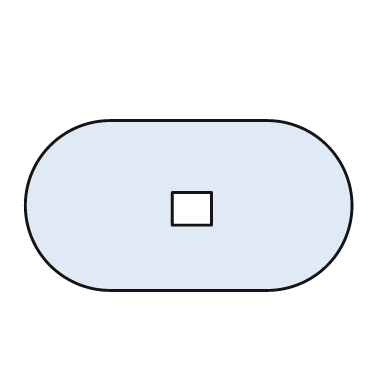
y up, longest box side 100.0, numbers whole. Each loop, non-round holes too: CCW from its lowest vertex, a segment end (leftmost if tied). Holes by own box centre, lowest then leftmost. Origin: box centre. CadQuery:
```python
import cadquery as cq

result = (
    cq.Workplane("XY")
    .moveTo(-24.0, -26.0)
    .lineTo(24.0, -26.0)
    .threePointArc((50.0, 0.0), (24.0, 26.0))
    .lineTo(-24.0, 26.0)
    .threePointArc((-50.0, 0.0), (-24.0, -26.0))
    .close()
    .moveTo(-5.0, -6.0)
    .lineTo(7.0, -6.0)
    .lineTo(7.0, 4.0)
    .lineTo(-5.0, 4.0)
    .close()
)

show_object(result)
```